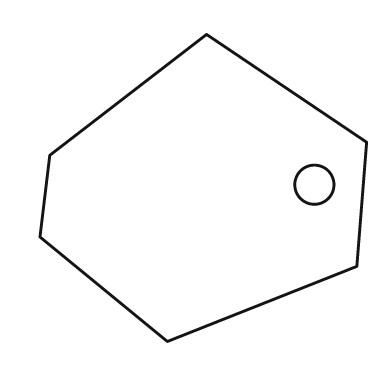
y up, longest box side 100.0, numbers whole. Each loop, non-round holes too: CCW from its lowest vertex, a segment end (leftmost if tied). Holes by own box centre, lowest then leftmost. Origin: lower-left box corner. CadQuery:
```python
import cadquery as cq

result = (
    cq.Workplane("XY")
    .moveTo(39.0, 0.0)
    .lineTo(97.0, 23.0)
    .lineTo(100.0, 61.0)
    .lineTo(51.0, 94.0)
    .lineTo(3.0, 57.0)
    .lineTo(0.0, 32.0)
    .close()
    .moveTo(84.0, 48.0)
    .circle(6.0)
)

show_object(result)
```